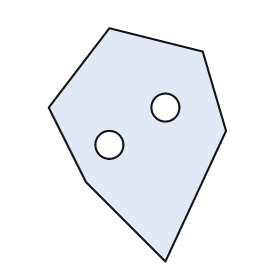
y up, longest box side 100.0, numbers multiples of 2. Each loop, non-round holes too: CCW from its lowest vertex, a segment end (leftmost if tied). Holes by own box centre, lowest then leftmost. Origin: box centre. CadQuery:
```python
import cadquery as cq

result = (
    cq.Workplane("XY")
    .moveTo(12.0, -50.0)
    .lineTo(38.0, 6.0)
    .lineTo(28.0, 40.0)
    .lineTo(-12.0, 50.0)
    .lineTo(-38.0, 16.0)
    .lineTo(-22.0, -16.0)
    .close()
    .moveTo(-12.0, 0.0)
    .circle(6.0)
    .moveTo(12.0, 16.0)
    .circle(6.0)
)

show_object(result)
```